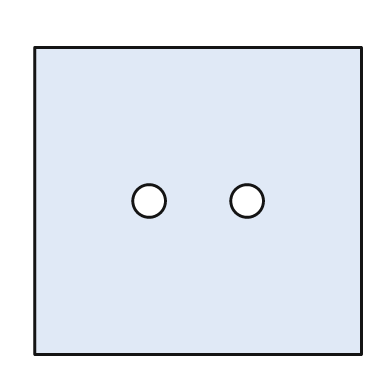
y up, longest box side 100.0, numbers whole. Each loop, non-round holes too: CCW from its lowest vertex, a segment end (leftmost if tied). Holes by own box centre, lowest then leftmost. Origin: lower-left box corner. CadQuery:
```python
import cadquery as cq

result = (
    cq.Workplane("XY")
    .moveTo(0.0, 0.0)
    .lineTo(100.0, 0.0)
    .lineTo(100.0, 94.0)
    .lineTo(0.0, 94.0)
    .close()
    .moveTo(35.0, 47.0)
    .circle(5.0)
    .moveTo(65.0, 47.0)
    .circle(5.0)
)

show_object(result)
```